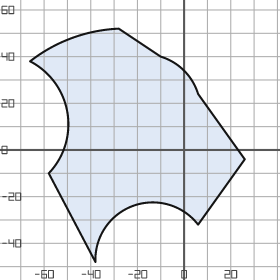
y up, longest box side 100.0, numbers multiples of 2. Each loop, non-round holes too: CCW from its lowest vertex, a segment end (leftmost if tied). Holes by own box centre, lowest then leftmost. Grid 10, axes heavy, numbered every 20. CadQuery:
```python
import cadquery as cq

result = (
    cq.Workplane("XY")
    .moveTo(-38.0, -48.0)
    .threePointArc((-22.0, -24.0), (6.0, -32.0))
    .lineTo(26.0, -4.0)
    .lineTo(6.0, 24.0)
    .threePointArc((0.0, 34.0), (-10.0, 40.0))
    .lineTo(-28.0, 52.0)
    .threePointArc((-48.0, 48.0), (-66.0, 38.0))
    .threePointArc((-50.0, 16.0), (-58.0, -10.0))
    .close()
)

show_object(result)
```